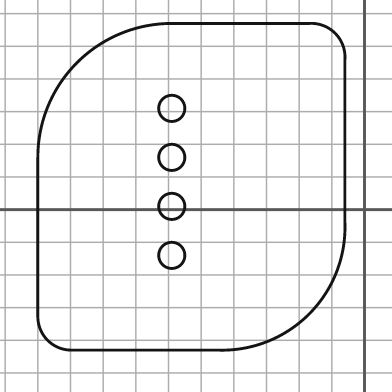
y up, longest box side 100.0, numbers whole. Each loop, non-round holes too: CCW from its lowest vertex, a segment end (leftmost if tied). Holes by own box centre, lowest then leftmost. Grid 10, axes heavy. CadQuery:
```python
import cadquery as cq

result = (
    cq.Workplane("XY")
    .moveTo(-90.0, -43.0)
    .lineTo(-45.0, -43.0)
    .threePointArc((-17.0, -32.0), (-6.0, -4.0))
    .lineTo(-6.0, 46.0)
    .threePointArc((-9.0, 54.0), (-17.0, 57.0))
    .lineTo(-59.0, 57.0)
    .threePointArc((-88.0, 45.0), (-100.0, 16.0))
    .lineTo(-100.0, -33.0)
    .threePointArc((-97.0, -40.0), (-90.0, -43.0))
    .close()
    .moveTo(-59.0, -14.0)
    .circle(4.0)
    .moveTo(-59.0, 1.0)
    .circle(4.0)
    .moveTo(-59.0, 16.0)
    .circle(4.0)
    .moveTo(-59.0, 31.0)
    .circle(4.0)
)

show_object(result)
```